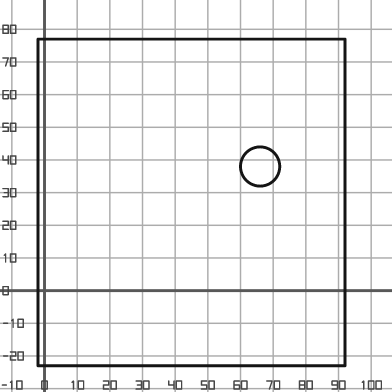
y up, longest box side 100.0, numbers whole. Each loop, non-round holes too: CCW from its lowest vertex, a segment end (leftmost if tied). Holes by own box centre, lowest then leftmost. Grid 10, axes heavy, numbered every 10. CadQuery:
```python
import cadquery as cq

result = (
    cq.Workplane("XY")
    .moveTo(-2.0, -23.0)
    .lineTo(92.0, -23.0)
    .lineTo(92.0, 77.0)
    .lineTo(-2.0, 77.0)
    .close()
    .moveTo(66.0, 38.0)
    .circle(6.0)
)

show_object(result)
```